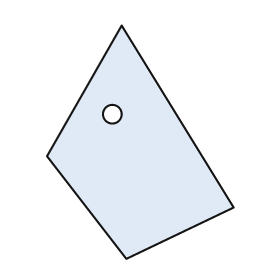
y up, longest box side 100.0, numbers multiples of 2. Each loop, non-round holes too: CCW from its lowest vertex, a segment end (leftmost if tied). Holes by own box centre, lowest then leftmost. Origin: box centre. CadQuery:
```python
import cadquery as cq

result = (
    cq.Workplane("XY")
    .moveTo(-6.0, -50.0)
    .lineTo(40.0, -28.0)
    .lineTo(-8.0, 50.0)
    .lineTo(-40.0, -6.0)
    .close()
    .moveTo(-12.0, 12.0)
    .circle(4.0)
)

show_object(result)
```